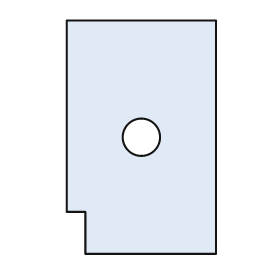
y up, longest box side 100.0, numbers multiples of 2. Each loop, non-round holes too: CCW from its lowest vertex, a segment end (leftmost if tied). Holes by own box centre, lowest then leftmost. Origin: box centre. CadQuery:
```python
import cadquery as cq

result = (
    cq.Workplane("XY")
    .moveTo(-24.0, -50.0)
    .lineTo(32.0, -50.0)
    .lineTo(32.0, 50.0)
    .lineTo(-32.0, 50.0)
    .lineTo(-32.0, -32.0)
    .lineTo(-24.0, -32.0)
    .close()
    .moveTo(0.0, 0.0)
    .circle(8.0)
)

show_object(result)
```